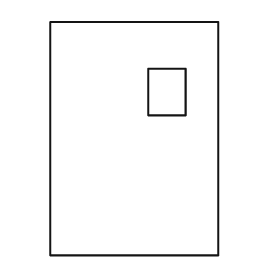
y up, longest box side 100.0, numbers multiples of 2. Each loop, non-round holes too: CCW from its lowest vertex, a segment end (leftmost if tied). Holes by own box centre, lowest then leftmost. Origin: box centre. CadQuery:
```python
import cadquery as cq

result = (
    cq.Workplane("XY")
    .moveTo(-36.0, -50.0)
    .lineTo(36.0, -50.0)
    .lineTo(36.0, 50.0)
    .lineTo(-36.0, 50.0)
    .close()
    .moveTo(6.0, 10.0)
    .lineTo(22.0, 10.0)
    .lineTo(22.0, 30.0)
    .lineTo(6.0, 30.0)
    .close()
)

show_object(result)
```